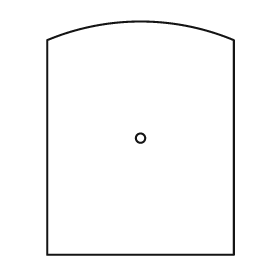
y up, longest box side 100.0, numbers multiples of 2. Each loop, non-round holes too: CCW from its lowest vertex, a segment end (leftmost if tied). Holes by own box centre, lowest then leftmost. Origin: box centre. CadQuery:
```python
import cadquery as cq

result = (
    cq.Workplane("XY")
    .moveTo(-40.0, -50.0)
    .lineTo(40.0, -50.0)
    .lineTo(40.0, 42.0)
    .threePointArc((0.0, 50.0), (-40.0, 42.0))
    .close()
    .moveTo(0.0, 0.0)
    .circle(2.0)
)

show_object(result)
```